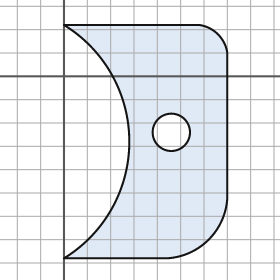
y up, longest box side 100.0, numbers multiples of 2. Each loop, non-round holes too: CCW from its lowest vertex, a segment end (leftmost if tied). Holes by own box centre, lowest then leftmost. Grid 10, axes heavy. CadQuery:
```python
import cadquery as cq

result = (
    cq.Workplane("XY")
    .moveTo(0.0, -78.0)
    .lineTo(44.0, -78.0)
    .threePointArc((62.0, -70.0), (70.0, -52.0))
    .lineTo(70.0, 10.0)
    .threePointArc((66.0, 18.0), (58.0, 22.0))
    .lineTo(0.0, 22.0)
    .threePointArc((28.0, -28.0), (0.0, -78.0))
    .close()
    .moveTo(46.0, -24.0)
    .circle(8.0)
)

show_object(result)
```